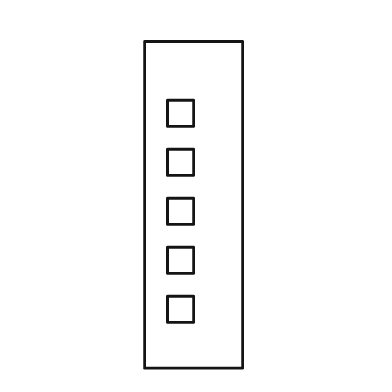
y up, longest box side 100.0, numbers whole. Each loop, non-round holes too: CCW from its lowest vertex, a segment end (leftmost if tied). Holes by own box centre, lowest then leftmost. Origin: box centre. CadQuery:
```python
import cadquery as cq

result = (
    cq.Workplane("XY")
    .moveTo(-15.0, -50.0)
    .lineTo(15.0, -50.0)
    .lineTo(15.0, 50.0)
    .lineTo(-15.0, 50.0)
    .close()
    .moveTo(-8.0, -36.0)
    .lineTo(0.0, -36.0)
    .lineTo(0.0, -28.0)
    .lineTo(-8.0, -28.0)
    .close()
    .moveTo(-8.0, -21.0)
    .lineTo(0.0, -21.0)
    .lineTo(0.0, -13.0)
    .lineTo(-8.0, -13.0)
    .close()
    .moveTo(-8.0, -6.0)
    .lineTo(0.0, -6.0)
    .lineTo(0.0, 2.0)
    .lineTo(-8.0, 2.0)
    .close()
    .moveTo(-8.0, 9.0)
    .lineTo(0.0, 9.0)
    .lineTo(0.0, 17.0)
    .lineTo(-8.0, 17.0)
    .close()
    .moveTo(-8.0, 24.0)
    .lineTo(0.0, 24.0)
    .lineTo(0.0, 32.0)
    .lineTo(-8.0, 32.0)
    .close()
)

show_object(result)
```